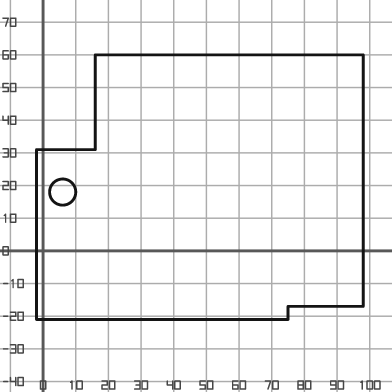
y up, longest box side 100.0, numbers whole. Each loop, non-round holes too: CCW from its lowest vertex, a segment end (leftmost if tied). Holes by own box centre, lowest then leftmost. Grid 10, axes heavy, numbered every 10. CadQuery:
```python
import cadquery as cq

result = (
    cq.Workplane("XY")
    .moveTo(-2.0, -21.0)
    .lineTo(75.0, -21.0)
    .lineTo(75.0, -17.0)
    .lineTo(98.0, -17.0)
    .lineTo(98.0, 60.0)
    .lineTo(16.0, 60.0)
    .lineTo(16.0, 31.0)
    .lineTo(-2.0, 31.0)
    .close()
    .moveTo(6.0, 18.0)
    .circle(4.0)
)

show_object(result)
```